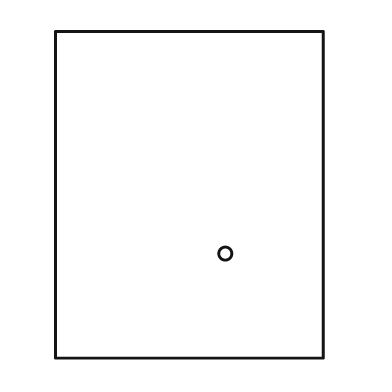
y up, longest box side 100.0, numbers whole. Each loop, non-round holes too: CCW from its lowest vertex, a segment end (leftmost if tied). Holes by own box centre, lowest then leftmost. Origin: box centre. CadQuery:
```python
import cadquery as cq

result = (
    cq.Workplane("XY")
    .moveTo(-41.0, -50.0)
    .lineTo(41.0, -50.0)
    .lineTo(41.0, 50.0)
    .lineTo(-41.0, 50.0)
    .close()
    .moveTo(11.0, -18.0)
    .circle(2.0)
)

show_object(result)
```